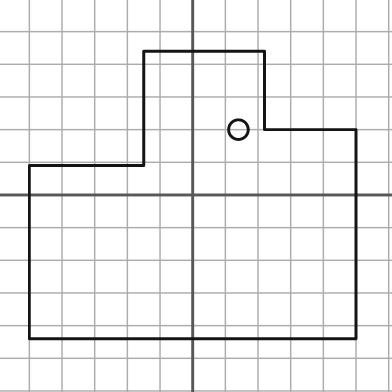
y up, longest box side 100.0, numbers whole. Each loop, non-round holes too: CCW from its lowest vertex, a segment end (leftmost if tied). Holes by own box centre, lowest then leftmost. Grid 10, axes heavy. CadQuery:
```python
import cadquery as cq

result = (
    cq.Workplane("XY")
    .moveTo(-50.0, -44.0)
    .lineTo(50.0, -44.0)
    .lineTo(50.0, 20.0)
    .lineTo(22.0, 20.0)
    .lineTo(22.0, 44.0)
    .lineTo(-15.0, 44.0)
    .lineTo(-15.0, 9.0)
    .lineTo(-50.0, 9.0)
    .close()
    .moveTo(14.0, 20.0)
    .circle(3.0)
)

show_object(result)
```